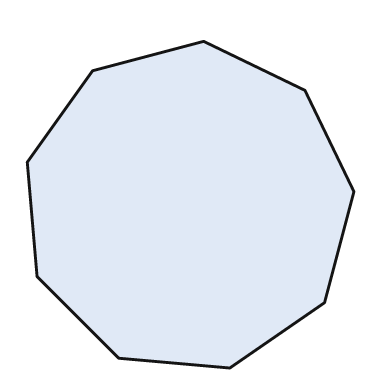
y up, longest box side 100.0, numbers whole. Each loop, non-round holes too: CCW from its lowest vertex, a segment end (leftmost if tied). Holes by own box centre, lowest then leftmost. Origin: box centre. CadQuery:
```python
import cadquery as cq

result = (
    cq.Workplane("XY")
    .moveTo(12.0, -50.0)
    .lineTo(41.0, -30.0)
    .lineTo(50.0, 4.0)
    .lineTo(35.0, 35.0)
    .lineTo(4.0, 50.0)
    .lineTo(-30.0, 41.0)
    .lineTo(-50.0, 13.0)
    .lineTo(-47.0, -22.0)
    .lineTo(-22.0, -47.0)
    .close()
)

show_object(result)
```